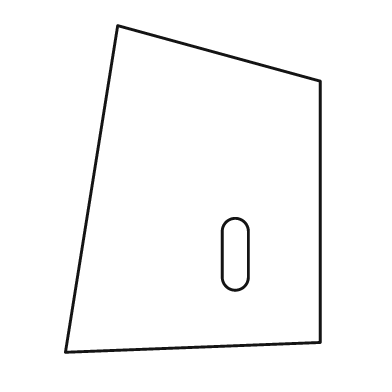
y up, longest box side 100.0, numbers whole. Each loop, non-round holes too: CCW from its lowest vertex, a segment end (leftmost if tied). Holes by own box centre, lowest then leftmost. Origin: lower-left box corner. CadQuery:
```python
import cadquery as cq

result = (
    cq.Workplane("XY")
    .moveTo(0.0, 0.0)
    .lineTo(78.0, 3.0)
    .lineTo(78.0, 83.0)
    .lineTo(16.0, 100.0)
    .close()
    .moveTo(48.0, 23.0)
    .threePointArc((52.0, 19.0), (56.0, 23.0))
    .lineTo(56.0, 37.0)
    .threePointArc((52.0, 41.0), (48.0, 37.0))
    .close()
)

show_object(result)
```